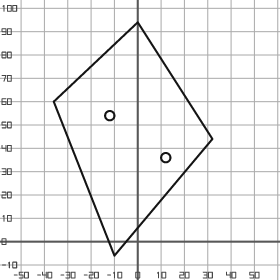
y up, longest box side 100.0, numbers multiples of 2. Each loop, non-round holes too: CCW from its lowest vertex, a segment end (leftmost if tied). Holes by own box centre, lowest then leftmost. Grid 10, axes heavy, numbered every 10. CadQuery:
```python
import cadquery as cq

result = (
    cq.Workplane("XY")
    .moveTo(-10.0, -6.0)
    .lineTo(32.0, 44.0)
    .lineTo(0.0, 94.0)
    .lineTo(-36.0, 60.0)
    .close()
    .moveTo(12.0, 36.0)
    .circle(2.0)
    .moveTo(-12.0, 54.0)
    .circle(2.0)
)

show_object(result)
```